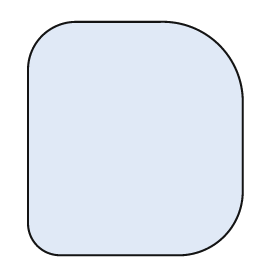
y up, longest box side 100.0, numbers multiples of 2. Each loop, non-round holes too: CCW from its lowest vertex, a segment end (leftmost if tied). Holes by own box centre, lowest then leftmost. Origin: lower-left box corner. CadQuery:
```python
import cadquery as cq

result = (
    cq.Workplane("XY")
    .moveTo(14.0, 0.0)
    .lineTo(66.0, 0.0)
    .threePointArc((84.0, 8.0), (92.0, 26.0))
    .lineTo(92.0, 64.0)
    .threePointArc((82.0, 90.0), (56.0, 100.0))
    .lineTo(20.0, 100.0)
    .threePointArc((6.0, 94.0), (0.0, 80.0))
    .lineTo(0.0, 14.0)
    .threePointArc((4.0, 4.0), (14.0, 0.0))
    .close()
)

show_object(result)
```